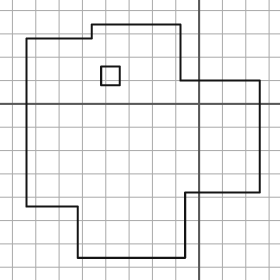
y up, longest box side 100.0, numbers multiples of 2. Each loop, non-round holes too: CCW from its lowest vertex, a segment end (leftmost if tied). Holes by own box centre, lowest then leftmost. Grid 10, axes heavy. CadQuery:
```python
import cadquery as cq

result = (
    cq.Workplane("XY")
    .moveTo(-52.0, -66.0)
    .lineTo(-6.0, -66.0)
    .lineTo(-6.0, -38.0)
    .lineTo(26.0, -38.0)
    .lineTo(26.0, 10.0)
    .lineTo(-8.0, 10.0)
    .lineTo(-8.0, 34.0)
    .lineTo(-46.0, 34.0)
    .lineTo(-46.0, 28.0)
    .lineTo(-74.0, 28.0)
    .lineTo(-74.0, -44.0)
    .lineTo(-52.0, -44.0)
    .close()
    .moveTo(-42.0, 8.0)
    .lineTo(-34.0, 8.0)
    .lineTo(-34.0, 16.0)
    .lineTo(-42.0, 16.0)
    .close()
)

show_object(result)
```